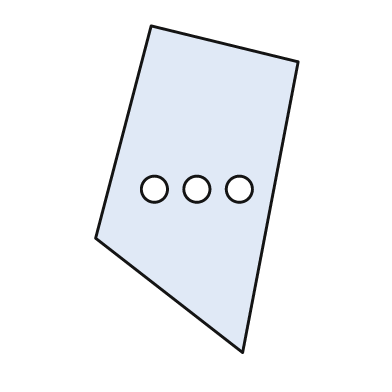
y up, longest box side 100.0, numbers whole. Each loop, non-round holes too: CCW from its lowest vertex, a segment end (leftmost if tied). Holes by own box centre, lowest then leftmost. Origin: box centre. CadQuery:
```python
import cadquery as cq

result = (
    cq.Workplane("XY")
    .moveTo(14.0, -50.0)
    .lineTo(31.0, 39.0)
    .lineTo(-14.0, 50.0)
    .lineTo(-31.0, -15.0)
    .close()
    .moveTo(-13.0, 0.0)
    .circle(4.0)
    .moveTo(0.0, 0.0)
    .circle(4.0)
    .moveTo(13.0, 0.0)
    .circle(4.0)
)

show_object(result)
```